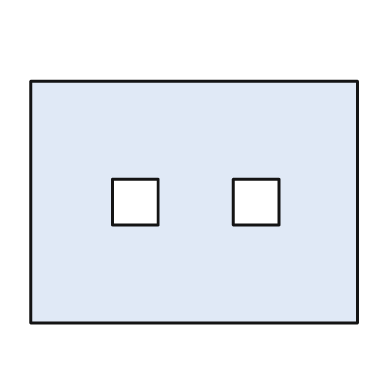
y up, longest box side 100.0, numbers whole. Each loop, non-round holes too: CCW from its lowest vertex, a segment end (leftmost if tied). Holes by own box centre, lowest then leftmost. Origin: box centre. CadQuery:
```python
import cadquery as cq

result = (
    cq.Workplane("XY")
    .moveTo(-50.0, -37.0)
    .lineTo(50.0, -37.0)
    .lineTo(50.0, 37.0)
    .lineTo(-50.0, 37.0)
    .close()
    .moveTo(-25.0, -7.0)
    .lineTo(-11.0, -7.0)
    .lineTo(-11.0, 7.0)
    .lineTo(-25.0, 7.0)
    .close()
    .moveTo(12.0, -7.0)
    .lineTo(26.0, -7.0)
    .lineTo(26.0, 7.0)
    .lineTo(12.0, 7.0)
    .close()
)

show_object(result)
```